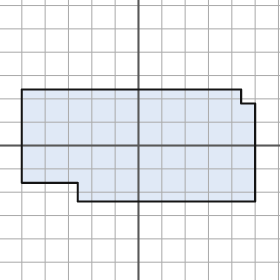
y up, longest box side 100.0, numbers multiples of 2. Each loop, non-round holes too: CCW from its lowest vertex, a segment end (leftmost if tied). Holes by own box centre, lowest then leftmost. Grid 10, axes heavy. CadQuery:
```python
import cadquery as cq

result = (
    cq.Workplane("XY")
    .moveTo(-26.0, -24.0)
    .lineTo(50.0, -24.0)
    .lineTo(50.0, 18.0)
    .lineTo(44.0, 18.0)
    .lineTo(44.0, 24.0)
    .lineTo(-50.0, 24.0)
    .lineTo(-50.0, -16.0)
    .lineTo(-26.0, -16.0)
    .close()
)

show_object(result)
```